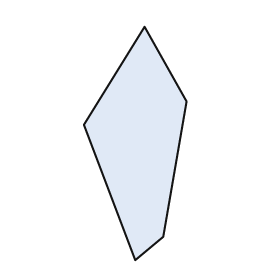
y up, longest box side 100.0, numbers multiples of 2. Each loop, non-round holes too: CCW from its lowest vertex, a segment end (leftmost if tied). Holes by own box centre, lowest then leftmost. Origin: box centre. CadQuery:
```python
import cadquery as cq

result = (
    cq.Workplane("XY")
    .moveTo(0.0, -50.0)
    .lineTo(12.0, -40.0)
    .lineTo(22.0, 18.0)
    .lineTo(4.0, 50.0)
    .lineTo(-22.0, 8.0)
    .close()
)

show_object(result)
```